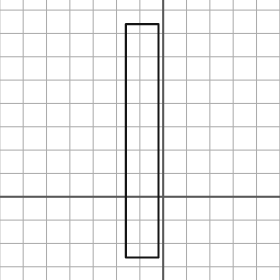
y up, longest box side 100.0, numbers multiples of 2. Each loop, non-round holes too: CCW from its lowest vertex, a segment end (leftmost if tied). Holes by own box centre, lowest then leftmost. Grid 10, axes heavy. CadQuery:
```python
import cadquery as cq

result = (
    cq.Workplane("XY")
    .moveTo(-16.0, -26.0)
    .lineTo(-2.0, -26.0)
    .lineTo(-2.0, 74.0)
    .lineTo(-16.0, 74.0)
    .close()
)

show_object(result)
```